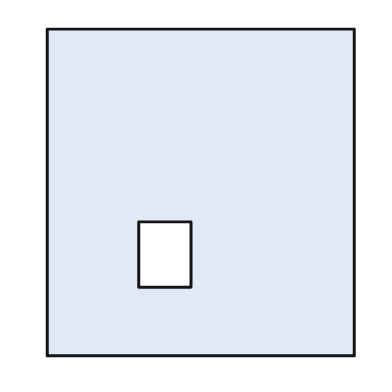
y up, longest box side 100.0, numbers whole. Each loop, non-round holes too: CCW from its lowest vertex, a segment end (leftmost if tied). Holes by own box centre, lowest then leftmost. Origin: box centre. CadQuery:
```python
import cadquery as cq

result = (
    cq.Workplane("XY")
    .moveTo(-47.0, -50.0)
    .lineTo(47.0, -50.0)
    .lineTo(47.0, 50.0)
    .lineTo(-47.0, 50.0)
    .close()
    .moveTo(-19.0, -29.0)
    .lineTo(-3.0, -29.0)
    .lineTo(-3.0, -9.0)
    .lineTo(-19.0, -9.0)
    .close()
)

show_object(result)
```